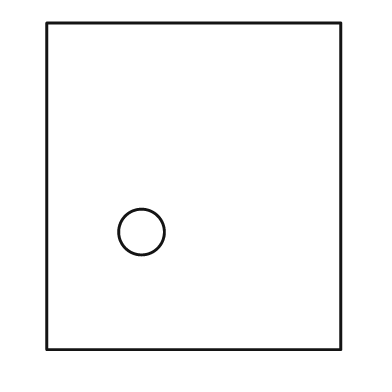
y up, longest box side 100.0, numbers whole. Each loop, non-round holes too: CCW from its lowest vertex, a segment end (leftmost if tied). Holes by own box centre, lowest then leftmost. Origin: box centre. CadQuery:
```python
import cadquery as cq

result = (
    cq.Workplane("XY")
    .moveTo(-45.0, -50.0)
    .lineTo(45.0, -50.0)
    .lineTo(45.0, 50.0)
    .lineTo(-45.0, 50.0)
    .close()
    .moveTo(-16.0, -14.0)
    .circle(7.0)
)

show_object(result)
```